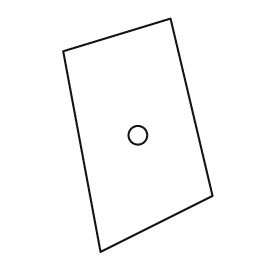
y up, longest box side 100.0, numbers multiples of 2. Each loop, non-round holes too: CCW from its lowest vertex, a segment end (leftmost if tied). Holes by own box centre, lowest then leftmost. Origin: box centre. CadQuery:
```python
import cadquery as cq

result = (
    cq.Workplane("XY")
    .moveTo(-16.0, -50.0)
    .lineTo(32.0, -26.0)
    .lineTo(14.0, 50.0)
    .lineTo(-32.0, 36.0)
    .close()
    .moveTo(0.0, 0.0)
    .circle(4.0)
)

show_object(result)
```